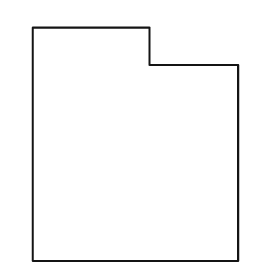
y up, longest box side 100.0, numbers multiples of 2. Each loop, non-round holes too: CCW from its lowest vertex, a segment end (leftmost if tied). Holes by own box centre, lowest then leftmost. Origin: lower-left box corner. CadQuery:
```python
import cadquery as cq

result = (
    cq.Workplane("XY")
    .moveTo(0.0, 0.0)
    .lineTo(88.0, 0.0)
    .lineTo(88.0, 84.0)
    .lineTo(50.0, 84.0)
    .lineTo(50.0, 100.0)
    .lineTo(0.0, 100.0)
    .close()
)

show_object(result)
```